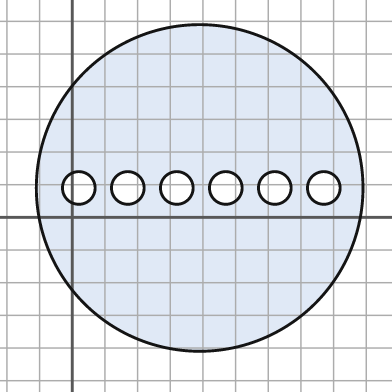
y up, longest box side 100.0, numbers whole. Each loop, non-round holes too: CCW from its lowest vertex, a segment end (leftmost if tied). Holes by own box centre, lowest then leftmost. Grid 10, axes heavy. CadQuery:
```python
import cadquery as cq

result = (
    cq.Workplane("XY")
    .moveTo(39.0, 9.0)
    .circle(50.0)
    .moveTo(2.0, 9.0)
    .circle(5.0)
    .moveTo(17.0, 9.0)
    .circle(5.0)
    .moveTo(32.0, 9.0)
    .circle(5.0)
    .moveTo(47.0, 9.0)
    .circle(5.0)
    .moveTo(62.0, 9.0)
    .circle(5.0)
    .moveTo(77.0, 9.0)
    .circle(5.0)
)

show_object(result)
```